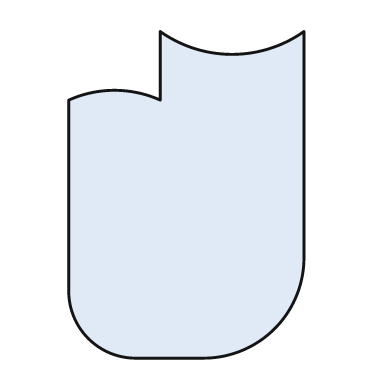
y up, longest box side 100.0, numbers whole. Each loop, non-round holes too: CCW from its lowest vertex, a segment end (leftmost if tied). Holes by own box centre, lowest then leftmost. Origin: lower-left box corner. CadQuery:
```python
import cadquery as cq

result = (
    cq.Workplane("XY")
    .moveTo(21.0, 0.0)
    .lineTo(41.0, 0.0)
    .threePointArc((63.0, 9.0), (72.0, 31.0))
    .lineTo(72.0, 100.0)
    .threePointArc((50.0, 93.0), (28.0, 100.0))
    .lineTo(28.0, 79.0)
    .threePointArc((14.0, 82.0), (0.0, 79.0))
    .lineTo(0.0, 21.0)
    .threePointArc((6.0, 6.0), (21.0, 0.0))
    .close()
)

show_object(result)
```